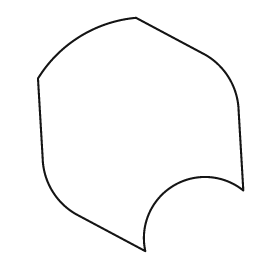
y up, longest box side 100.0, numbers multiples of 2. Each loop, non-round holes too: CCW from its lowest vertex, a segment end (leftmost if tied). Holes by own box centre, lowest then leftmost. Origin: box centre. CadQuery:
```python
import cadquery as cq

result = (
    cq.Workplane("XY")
    .moveTo(2.0, -50.0)
    .threePointArc((14.0, -22.0), (44.0, -24.0))
    .lineTo(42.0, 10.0)
    .threePointArc((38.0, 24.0), (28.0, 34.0))
    .lineTo(-2.0, 50.0)
    .threePointArc((-26.0, 42.0), (-44.0, 24.0))
    .lineTo(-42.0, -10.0)
    .threePointArc((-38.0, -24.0), (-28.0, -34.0))
    .close()
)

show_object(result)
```